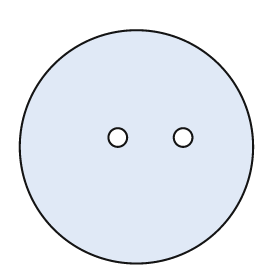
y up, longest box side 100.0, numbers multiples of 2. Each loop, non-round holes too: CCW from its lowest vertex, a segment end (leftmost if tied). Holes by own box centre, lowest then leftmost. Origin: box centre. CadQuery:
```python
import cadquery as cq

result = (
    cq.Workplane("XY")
    .moveTo(0.0, 0.0)
    .circle(50.0)
    .moveTo(-8.0, 4.0)
    .circle(4.0)
    .moveTo(20.0, 4.0)
    .circle(4.0)
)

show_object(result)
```